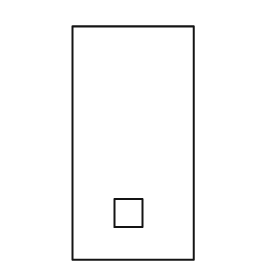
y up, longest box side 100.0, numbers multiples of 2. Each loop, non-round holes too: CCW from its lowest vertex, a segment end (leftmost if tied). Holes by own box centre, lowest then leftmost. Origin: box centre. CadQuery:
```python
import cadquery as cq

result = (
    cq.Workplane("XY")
    .moveTo(-26.0, -50.0)
    .lineTo(26.0, -50.0)
    .lineTo(26.0, 50.0)
    .lineTo(-26.0, 50.0)
    .close()
    .moveTo(-8.0, -36.0)
    .lineTo(4.0, -36.0)
    .lineTo(4.0, -24.0)
    .lineTo(-8.0, -24.0)
    .close()
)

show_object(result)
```